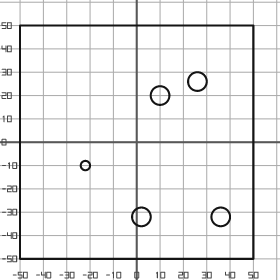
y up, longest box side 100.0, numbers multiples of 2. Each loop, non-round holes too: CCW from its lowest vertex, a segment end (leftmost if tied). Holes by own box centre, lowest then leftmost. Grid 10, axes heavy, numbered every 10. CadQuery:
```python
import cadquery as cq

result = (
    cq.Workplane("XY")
    .moveTo(-50.0, -50.0)
    .lineTo(50.0, -50.0)
    .lineTo(50.0, 50.0)
    .lineTo(-50.0, 50.0)
    .close()
    .moveTo(2.0, -32.0)
    .circle(4.0)
    .moveTo(36.0, -32.0)
    .circle(4.0)
    .moveTo(-22.0, -10.0)
    .circle(2.0)
    .moveTo(10.0, 20.0)
    .circle(4.0)
    .moveTo(26.0, 26.0)
    .circle(4.0)
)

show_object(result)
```